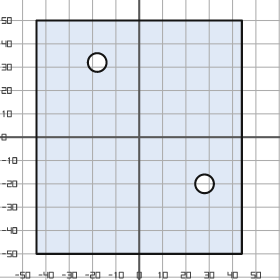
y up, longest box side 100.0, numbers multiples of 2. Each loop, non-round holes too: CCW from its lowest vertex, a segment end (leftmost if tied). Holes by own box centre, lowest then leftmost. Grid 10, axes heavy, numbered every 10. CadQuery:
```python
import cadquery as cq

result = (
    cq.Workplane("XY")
    .moveTo(-44.0, -50.0)
    .lineTo(44.0, -50.0)
    .lineTo(44.0, 50.0)
    .lineTo(-44.0, 50.0)
    .close()
    .moveTo(28.0, -20.0)
    .circle(4.0)
    .moveTo(-18.0, 32.0)
    .circle(4.0)
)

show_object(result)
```